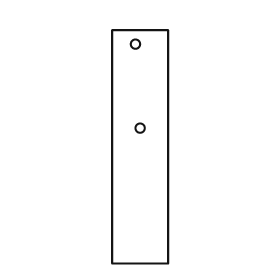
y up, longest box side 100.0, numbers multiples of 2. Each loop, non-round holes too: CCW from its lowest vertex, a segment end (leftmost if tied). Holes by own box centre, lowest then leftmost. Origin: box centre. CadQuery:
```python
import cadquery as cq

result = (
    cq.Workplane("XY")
    .moveTo(-12.0, -50.0)
    .lineTo(12.0, -50.0)
    .lineTo(12.0, 50.0)
    .lineTo(-12.0, 50.0)
    .close()
    .moveTo(0.0, 8.0)
    .circle(2.0)
    .moveTo(-2.0, 44.0)
    .circle(2.0)
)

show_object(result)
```